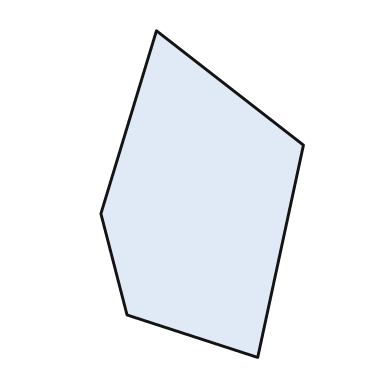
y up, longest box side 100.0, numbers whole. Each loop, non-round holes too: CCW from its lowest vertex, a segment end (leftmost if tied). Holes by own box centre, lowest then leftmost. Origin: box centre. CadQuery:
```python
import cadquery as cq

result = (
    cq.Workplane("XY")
    .moveTo(17.0, -50.0)
    .lineTo(31.0, 15.0)
    .lineTo(-14.0, 50.0)
    .lineTo(-31.0, -6.0)
    .lineTo(-23.0, -37.0)
    .close()
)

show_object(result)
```